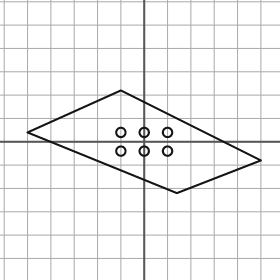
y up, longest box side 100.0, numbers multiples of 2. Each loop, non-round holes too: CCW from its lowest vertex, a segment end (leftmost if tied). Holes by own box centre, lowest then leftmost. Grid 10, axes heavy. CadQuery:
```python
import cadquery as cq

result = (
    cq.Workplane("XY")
    .moveTo(14.0, -22.0)
    .lineTo(50.0, -8.0)
    .lineTo(-10.0, 22.0)
    .lineTo(-50.0, 4.0)
    .close()
    .moveTo(-10.0, -4.0)
    .circle(2.0)
    .moveTo(0.0, -4.0)
    .circle(2.0)
    .moveTo(10.0, -4.0)
    .circle(2.0)
    .moveTo(-10.0, 4.0)
    .circle(2.0)
    .moveTo(0.0, 4.0)
    .circle(2.0)
    .moveTo(10.0, 4.0)
    .circle(2.0)
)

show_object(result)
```